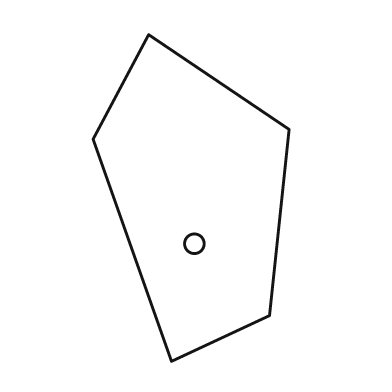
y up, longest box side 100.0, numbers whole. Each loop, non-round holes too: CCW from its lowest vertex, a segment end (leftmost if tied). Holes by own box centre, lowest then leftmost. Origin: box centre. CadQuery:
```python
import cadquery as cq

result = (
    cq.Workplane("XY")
    .moveTo(-6.0, -50.0)
    .lineTo(24.0, -36.0)
    .lineTo(30.0, 21.0)
    .lineTo(-13.0, 50.0)
    .lineTo(-30.0, 18.0)
    .close()
    .moveTo(1.0, -14.0)
    .circle(3.0)
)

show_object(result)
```